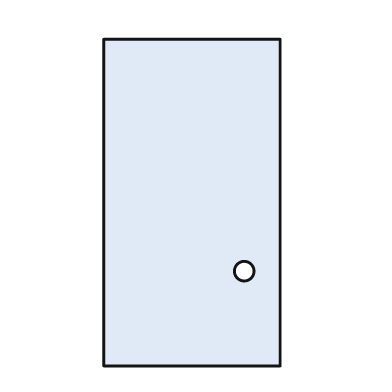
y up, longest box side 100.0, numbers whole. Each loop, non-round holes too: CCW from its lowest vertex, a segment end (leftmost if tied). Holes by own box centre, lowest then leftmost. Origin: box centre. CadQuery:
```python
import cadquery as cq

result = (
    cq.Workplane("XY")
    .moveTo(-27.0, -50.0)
    .lineTo(27.0, -50.0)
    .lineTo(27.0, 50.0)
    .lineTo(-27.0, 50.0)
    .close()
    .moveTo(16.0, -21.0)
    .circle(3.0)
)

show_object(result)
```